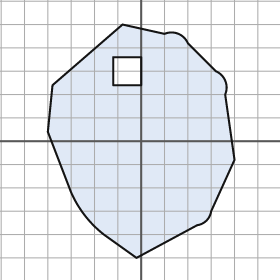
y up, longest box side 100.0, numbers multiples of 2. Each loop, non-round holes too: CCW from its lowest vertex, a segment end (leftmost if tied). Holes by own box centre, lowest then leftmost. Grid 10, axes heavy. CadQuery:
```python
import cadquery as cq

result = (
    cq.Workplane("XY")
    .moveTo(-2.0, -50.0)
    .lineTo(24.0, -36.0)
    .threePointArc((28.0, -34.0), (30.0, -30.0))
    .lineTo(40.0, -8.0)
    .lineTo(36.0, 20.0)
    .threePointArc((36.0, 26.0), (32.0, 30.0))
    .lineTo(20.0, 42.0)
    .threePointArc((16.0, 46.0), (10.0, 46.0))
    .lineTo(-8.0, 50.0)
    .lineTo(-38.0, 24.0)
    .lineTo(-40.0, 4.0)
    .lineTo(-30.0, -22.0)
    .threePointArc((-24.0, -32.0), (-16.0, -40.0))
    .close()
    .moveTo(-12.0, 24.0)
    .lineTo(0.0, 24.0)
    .lineTo(0.0, 36.0)
    .lineTo(-12.0, 36.0)
    .close()
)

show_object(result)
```